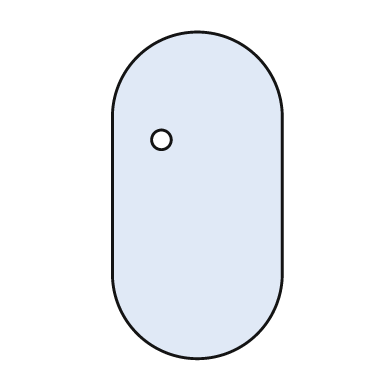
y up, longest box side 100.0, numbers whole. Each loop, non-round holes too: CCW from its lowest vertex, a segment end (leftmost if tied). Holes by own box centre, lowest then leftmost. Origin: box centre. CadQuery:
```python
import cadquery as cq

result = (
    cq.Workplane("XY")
    .moveTo(-26.0, -24.0)
    .threePointArc((0.0, -50.0), (26.0, -24.0))
    .lineTo(26.0, 24.0)
    .threePointArc((0.0, 50.0), (-26.0, 24.0))
    .close()
    .moveTo(-11.0, 17.0)
    .circle(3.0)
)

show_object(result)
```